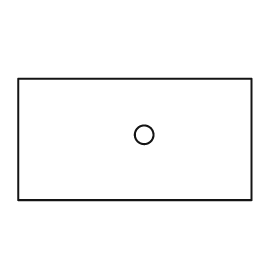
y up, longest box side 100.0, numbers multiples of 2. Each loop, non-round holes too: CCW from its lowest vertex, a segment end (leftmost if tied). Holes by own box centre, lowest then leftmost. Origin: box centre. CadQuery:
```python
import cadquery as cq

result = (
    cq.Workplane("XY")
    .moveTo(-50.0, -26.0)
    .lineTo(50.0, -26.0)
    .lineTo(50.0, 26.0)
    .lineTo(-50.0, 26.0)
    .close()
    .moveTo(4.0, 2.0)
    .circle(4.0)
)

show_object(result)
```